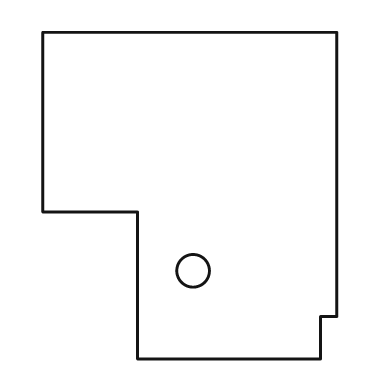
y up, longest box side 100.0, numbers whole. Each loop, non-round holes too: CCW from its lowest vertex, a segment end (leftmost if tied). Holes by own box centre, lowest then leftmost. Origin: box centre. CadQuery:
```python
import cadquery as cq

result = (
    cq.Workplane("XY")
    .moveTo(-16.0, -50.0)
    .lineTo(40.0, -50.0)
    .lineTo(40.0, -37.0)
    .lineTo(45.0, -37.0)
    .lineTo(45.0, 50.0)
    .lineTo(-45.0, 50.0)
    .lineTo(-45.0, -5.0)
    .lineTo(-16.0, -5.0)
    .close()
    .moveTo(1.0, -23.0)
    .circle(5.0)
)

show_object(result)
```